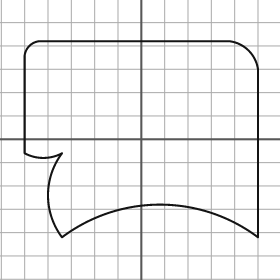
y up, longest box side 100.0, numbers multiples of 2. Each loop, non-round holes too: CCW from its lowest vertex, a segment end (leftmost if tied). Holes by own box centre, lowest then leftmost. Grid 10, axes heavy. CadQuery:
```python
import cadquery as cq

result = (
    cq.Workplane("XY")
    .moveTo(-34.0, -42.0)
    .threePointArc((8.0, -28.0), (50.0, -42.0))
    .lineTo(50.0, 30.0)
    .threePointArc((46.0, 38.0), (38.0, 42.0))
    .lineTo(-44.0, 42.0)
    .threePointArc((-48.0, 40.0), (-50.0, 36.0))
    .lineTo(-50.0, -6.0)
    .threePointArc((-42.0, -8.0), (-34.0, -6.0))
    .threePointArc((-40.0, -24.0), (-34.0, -42.0))
    .close()
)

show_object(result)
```